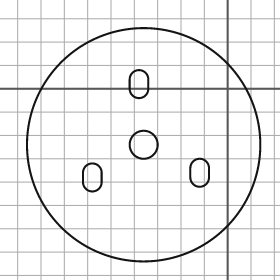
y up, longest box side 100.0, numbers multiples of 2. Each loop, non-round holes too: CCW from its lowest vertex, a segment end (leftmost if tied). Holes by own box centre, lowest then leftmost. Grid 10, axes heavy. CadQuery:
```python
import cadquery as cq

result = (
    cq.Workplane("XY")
    .moveTo(-36.0, -24.0)
    .circle(50.0)
    .moveTo(-62.0, -40.0)
    .threePointArc((-58.0, -44.0), (-54.0, -40.0))
    .lineTo(-54.0, -36.0)
    .threePointArc((-58.0, -32.0), (-62.0, -36.0))
    .close()
    .moveTo(-16.0, -38.0)
    .threePointArc((-12.0, -42.0), (-8.0, -38.0))
    .lineTo(-8.0, -34.0)
    .threePointArc((-12.0, -30.0), (-16.0, -34.0))
    .close()
    .moveTo(-36.0, -24.0)
    .circle(6.0)
    .moveTo(-42.0, 0.0)
    .threePointArc((-38.0, -4.0), (-34.0, 0.0))
    .lineTo(-34.0, 4.0)
    .threePointArc((-38.0, 8.0), (-42.0, 4.0))
    .close()
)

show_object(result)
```